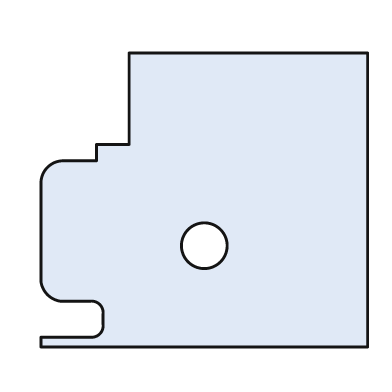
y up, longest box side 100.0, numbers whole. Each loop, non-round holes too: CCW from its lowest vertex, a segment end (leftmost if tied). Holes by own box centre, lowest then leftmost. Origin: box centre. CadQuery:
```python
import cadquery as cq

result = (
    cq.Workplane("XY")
    .moveTo(-50.0, -45.0)
    .lineTo(50.0, -45.0)
    .lineTo(50.0, 45.0)
    .lineTo(-23.0, 45.0)
    .lineTo(-23.0, 17.0)
    .lineTo(-33.0, 17.0)
    .lineTo(-33.0, 12.0)
    .lineTo(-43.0, 12.0)
    .threePointArc((-48.0, 10.0), (-50.0, 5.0))
    .lineTo(-50.0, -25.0)
    .threePointArc((-48.0, -29.0), (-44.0, -31.0))
    .lineTo(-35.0, -31.0)
    .threePointArc((-32.0, -32.0), (-31.0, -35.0))
    .lineTo(-31.0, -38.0)
    .threePointArc((-32.0, -41.0), (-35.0, -42.0))
    .lineTo(-50.0, -42.0)
    .close()
    .moveTo(0.0, -14.0)
    .circle(7.0)
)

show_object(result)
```